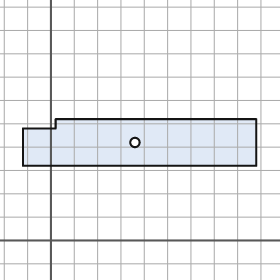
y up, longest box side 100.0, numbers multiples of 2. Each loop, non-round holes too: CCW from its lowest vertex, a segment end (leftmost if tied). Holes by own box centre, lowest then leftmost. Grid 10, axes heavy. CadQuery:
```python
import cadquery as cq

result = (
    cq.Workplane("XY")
    .moveTo(-12.0, 32.0)
    .lineTo(88.0, 32.0)
    .lineTo(88.0, 52.0)
    .lineTo(2.0, 52.0)
    .lineTo(2.0, 48.0)
    .lineTo(-12.0, 48.0)
    .close()
    .moveTo(36.0, 42.0)
    .circle(2.0)
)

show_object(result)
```